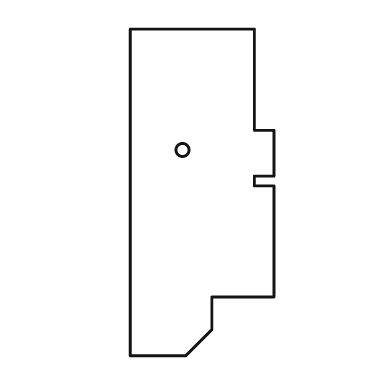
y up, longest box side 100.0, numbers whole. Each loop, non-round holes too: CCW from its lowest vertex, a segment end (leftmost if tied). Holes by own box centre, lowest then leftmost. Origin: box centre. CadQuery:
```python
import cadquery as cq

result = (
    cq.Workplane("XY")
    .moveTo(-22.0, -50.0)
    .lineTo(-5.0, -50.0)
    .lineTo(3.0, -42.0)
    .lineTo(3.0, -32.0)
    .lineTo(22.0, -32.0)
    .lineTo(22.0, 2.0)
    .lineTo(16.0, 2.0)
    .lineTo(16.0, 5.0)
    .lineTo(22.0, 5.0)
    .lineTo(22.0, 19.0)
    .lineTo(16.0, 19.0)
    .lineTo(16.0, 50.0)
    .lineTo(-22.0, 50.0)
    .close()
    .moveTo(-6.0, 13.0)
    .circle(2.0)
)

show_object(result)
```